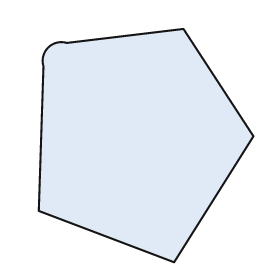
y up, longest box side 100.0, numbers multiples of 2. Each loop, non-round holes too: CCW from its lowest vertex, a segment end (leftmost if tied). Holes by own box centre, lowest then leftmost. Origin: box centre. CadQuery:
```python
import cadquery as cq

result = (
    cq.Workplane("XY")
    .moveTo(12.0, -50.0)
    .lineTo(46.0, 4.0)
    .lineTo(16.0, 50.0)
    .lineTo(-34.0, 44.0)
    .threePointArc((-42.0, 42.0), (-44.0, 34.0))
    .lineTo(-46.0, -28.0)
    .close()
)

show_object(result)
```